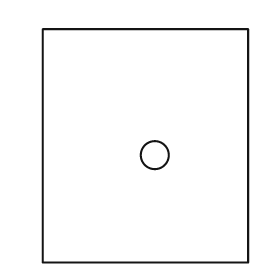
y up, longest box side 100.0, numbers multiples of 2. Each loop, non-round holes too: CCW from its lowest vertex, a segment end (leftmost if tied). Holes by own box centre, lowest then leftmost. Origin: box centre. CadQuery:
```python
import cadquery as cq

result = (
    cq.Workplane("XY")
    .moveTo(-44.0, -50.0)
    .lineTo(44.0, -50.0)
    .lineTo(44.0, 50.0)
    .lineTo(-44.0, 50.0)
    .close()
    .moveTo(4.0, -4.0)
    .circle(6.0)
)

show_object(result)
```